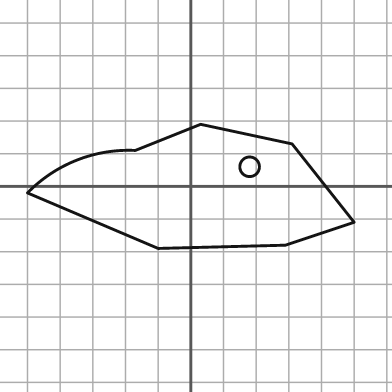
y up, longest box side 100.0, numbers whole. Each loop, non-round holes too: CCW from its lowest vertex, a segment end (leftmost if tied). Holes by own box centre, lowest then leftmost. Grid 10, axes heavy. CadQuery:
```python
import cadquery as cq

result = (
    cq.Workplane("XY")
    .moveTo(-10.0, -19.0)
    .lineTo(29.0, -18.0)
    .lineTo(50.0, -11.0)
    .lineTo(31.0, 13.0)
    .lineTo(3.0, 19.0)
    .lineTo(-17.0, 11.0)
    .threePointArc((-35.0, 8.0), (-50.0, -2.0))
    .close()
    .moveTo(18.0, 6.0)
    .circle(3.0)
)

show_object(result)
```